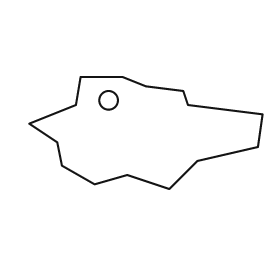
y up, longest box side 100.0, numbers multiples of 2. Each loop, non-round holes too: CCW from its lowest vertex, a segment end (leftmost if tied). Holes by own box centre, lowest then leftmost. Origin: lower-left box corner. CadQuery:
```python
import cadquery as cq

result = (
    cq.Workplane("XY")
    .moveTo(60.0, 0.0)
    .lineTo(72.0, 12.0)
    .lineTo(98.0, 18.0)
    .lineTo(100.0, 32.0)
    .lineTo(68.0, 36.0)
    .lineTo(66.0, 42.0)
    .lineTo(50.0, 44.0)
    .lineTo(40.0, 48.0)
    .lineTo(22.0, 48.0)
    .lineTo(20.0, 36.0)
    .lineTo(0.0, 28.0)
    .lineTo(12.0, 20.0)
    .lineTo(14.0, 10.0)
    .lineTo(28.0, 2.0)
    .lineTo(42.0, 6.0)
    .close()
    .moveTo(34.0, 38.0)
    .circle(4.0)
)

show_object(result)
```